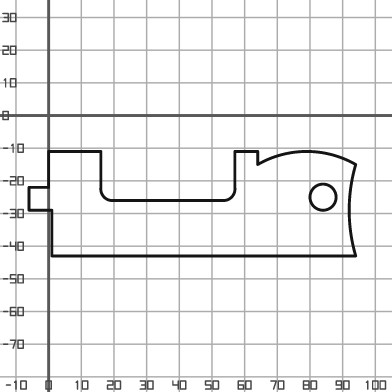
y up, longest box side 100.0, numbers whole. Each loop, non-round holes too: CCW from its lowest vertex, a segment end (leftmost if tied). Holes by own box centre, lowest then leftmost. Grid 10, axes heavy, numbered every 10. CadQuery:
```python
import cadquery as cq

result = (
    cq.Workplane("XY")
    .moveTo(1.0, -43.0)
    .lineTo(94.0, -43.0)
    .threePointArc((92.0, -29.0), (94.0, -15.0))
    .threePointArc((79.0, -11.0), (64.0, -15.0))
    .lineTo(64.0, -11.0)
    .lineTo(57.0, -11.0)
    .lineTo(57.0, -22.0)
    .threePointArc((56.0, -25.0), (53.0, -26.0))
    .lineTo(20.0, -26.0)
    .threePointArc((17.0, -25.0), (16.0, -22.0))
    .lineTo(16.0, -11.0)
    .lineTo(0.0, -11.0)
    .lineTo(0.0, -22.0)
    .lineTo(-6.0, -22.0)
    .lineTo(-6.0, -29.0)
    .lineTo(1.0, -29.0)
    .close()
    .moveTo(84.0, -25.0)
    .circle(4.0)
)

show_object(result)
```